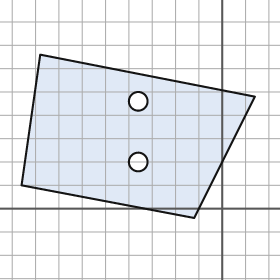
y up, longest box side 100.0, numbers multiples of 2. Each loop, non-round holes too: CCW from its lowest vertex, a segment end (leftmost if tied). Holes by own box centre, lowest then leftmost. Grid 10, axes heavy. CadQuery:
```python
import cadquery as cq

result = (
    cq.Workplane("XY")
    .moveTo(-12.0, -4.0)
    .lineTo(14.0, 48.0)
    .lineTo(-78.0, 66.0)
    .lineTo(-86.0, 10.0)
    .close()
    .moveTo(-36.0, 20.0)
    .circle(4.0)
    .moveTo(-36.0, 46.0)
    .circle(4.0)
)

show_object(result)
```